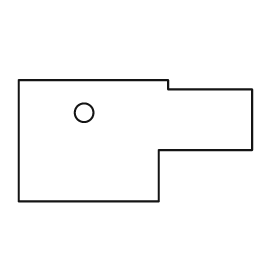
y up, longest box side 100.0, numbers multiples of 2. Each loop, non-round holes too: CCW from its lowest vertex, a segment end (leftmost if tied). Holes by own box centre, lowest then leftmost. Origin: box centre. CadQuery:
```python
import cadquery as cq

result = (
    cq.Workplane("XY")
    .moveTo(-50.0, -26.0)
    .lineTo(10.0, -26.0)
    .lineTo(10.0, -4.0)
    .lineTo(50.0, -4.0)
    .lineTo(50.0, 22.0)
    .lineTo(14.0, 22.0)
    .lineTo(14.0, 26.0)
    .lineTo(-50.0, 26.0)
    .close()
    .moveTo(-22.0, 12.0)
    .circle(4.0)
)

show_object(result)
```